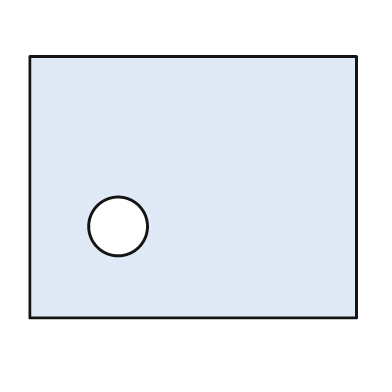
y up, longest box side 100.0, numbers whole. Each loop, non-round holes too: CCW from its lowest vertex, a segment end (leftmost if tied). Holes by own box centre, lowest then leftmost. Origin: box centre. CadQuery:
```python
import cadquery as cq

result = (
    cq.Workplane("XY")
    .moveTo(-50.0, -40.0)
    .lineTo(50.0, -40.0)
    .lineTo(50.0, 40.0)
    .lineTo(-50.0, 40.0)
    .close()
    .moveTo(-23.0, -12.0)
    .circle(9.0)
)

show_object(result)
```